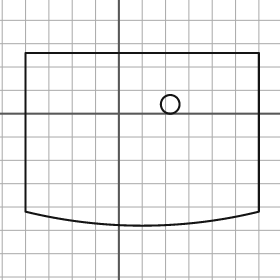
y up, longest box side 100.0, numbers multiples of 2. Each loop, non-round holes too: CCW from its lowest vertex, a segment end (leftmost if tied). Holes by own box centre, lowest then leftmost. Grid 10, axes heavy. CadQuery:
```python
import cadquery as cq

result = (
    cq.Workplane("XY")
    .moveTo(-40.0, -42.0)
    .threePointArc((10.0, -48.0), (60.0, -42.0))
    .lineTo(60.0, 26.0)
    .lineTo(-40.0, 26.0)
    .close()
    .moveTo(22.0, 4.0)
    .circle(4.0)
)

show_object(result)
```